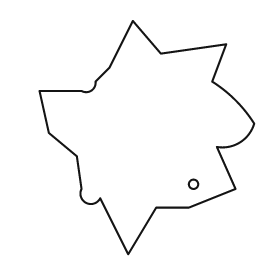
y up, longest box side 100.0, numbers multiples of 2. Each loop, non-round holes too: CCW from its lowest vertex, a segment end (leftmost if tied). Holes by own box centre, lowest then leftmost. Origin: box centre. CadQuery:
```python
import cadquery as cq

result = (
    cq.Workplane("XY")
    .moveTo(-8.0, -50.0)
    .lineTo(4.0, -30.0)
    .lineTo(18.0, -30.0)
    .lineTo(38.0, -22.0)
    .lineTo(30.0, -4.0)
    .threePointArc((40.0, -2.0), (46.0, 6.0))
    .threePointArc((38.0, 16.0), (28.0, 24.0))
    .lineTo(34.0, 40.0)
    .lineTo(6.0, 36.0)
    .lineTo(-6.0, 50.0)
    .lineTo(-16.0, 30.0)
    .lineTo(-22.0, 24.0)
    .threePointArc((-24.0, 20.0), (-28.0, 20.0))
    .lineTo(-46.0, 20.0)
    .lineTo(-42.0, 2.0)
    .lineTo(-30.0, -8.0)
    .lineTo(-28.0, -22.0)
    .threePointArc((-26.0, -28.0), (-20.0, -26.0))
    .close()
    .moveTo(20.0, -20.0)
    .circle(2.0)
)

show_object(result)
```